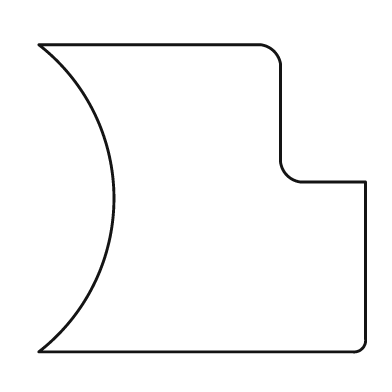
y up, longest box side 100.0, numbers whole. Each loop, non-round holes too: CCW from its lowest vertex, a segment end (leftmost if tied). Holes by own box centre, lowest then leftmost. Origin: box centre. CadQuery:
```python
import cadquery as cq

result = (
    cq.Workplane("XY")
    .moveTo(-50.0, -47.0)
    .lineTo(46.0, -47.0)
    .threePointArc((49.0, -46.0), (50.0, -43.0))
    .lineTo(50.0, 5.0)
    .lineTo(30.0, 5.0)
    .threePointArc((26.0, 7.0), (24.0, 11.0))
    .lineTo(24.0, 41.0)
    .threePointArc((22.0, 45.0), (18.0, 47.0))
    .lineTo(-50.0, 47.0)
    .threePointArc((-27.0, 0.0), (-50.0, -47.0))
    .close()
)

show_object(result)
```